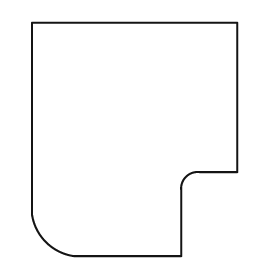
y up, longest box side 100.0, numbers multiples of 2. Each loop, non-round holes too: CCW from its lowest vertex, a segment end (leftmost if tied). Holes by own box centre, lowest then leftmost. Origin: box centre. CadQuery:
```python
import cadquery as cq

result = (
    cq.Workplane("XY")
    .moveTo(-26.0, -50.0)
    .lineTo(20.0, -50.0)
    .lineTo(20.0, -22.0)
    .threePointArc((22.0, -16.0), (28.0, -14.0))
    .lineTo(44.0, -14.0)
    .lineTo(44.0, 50.0)
    .lineTo(-44.0, 50.0)
    .lineTo(-44.0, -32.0)
    .threePointArc((-38.0, -44.0), (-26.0, -50.0))
    .close()
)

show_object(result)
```